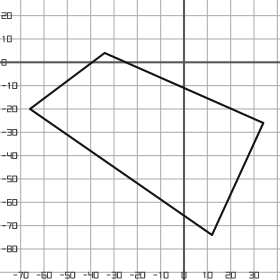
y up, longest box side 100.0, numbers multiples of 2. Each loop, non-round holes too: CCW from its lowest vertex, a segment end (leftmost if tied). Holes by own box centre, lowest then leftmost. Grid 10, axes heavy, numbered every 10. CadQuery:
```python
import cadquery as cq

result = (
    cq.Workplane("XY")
    .moveTo(12.0, -74.0)
    .lineTo(34.0, -26.0)
    .lineTo(-34.0, 4.0)
    .lineTo(-66.0, -20.0)
    .close()
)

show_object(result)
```